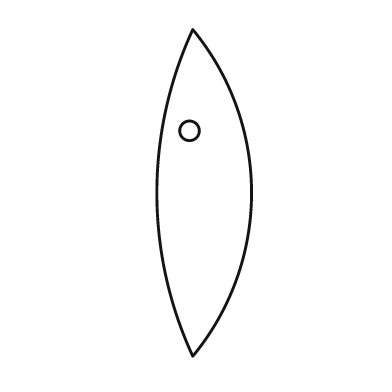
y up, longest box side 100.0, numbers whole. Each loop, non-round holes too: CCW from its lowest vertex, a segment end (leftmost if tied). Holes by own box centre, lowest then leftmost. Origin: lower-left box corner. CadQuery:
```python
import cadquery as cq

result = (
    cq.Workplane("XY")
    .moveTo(11.0, 0.0)
    .threePointArc((29.0, 50.0), (11.0, 100.0))
    .threePointArc((0.0, 50.0), (11.0, 0.0))
    .close()
    .moveTo(10.0, 69.0)
    .circle(3.0)
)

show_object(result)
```